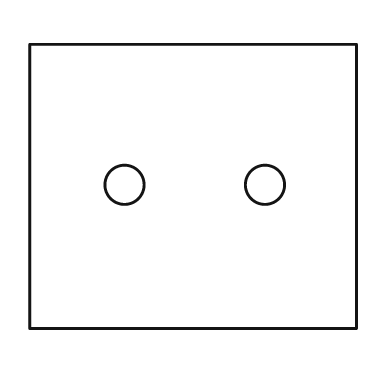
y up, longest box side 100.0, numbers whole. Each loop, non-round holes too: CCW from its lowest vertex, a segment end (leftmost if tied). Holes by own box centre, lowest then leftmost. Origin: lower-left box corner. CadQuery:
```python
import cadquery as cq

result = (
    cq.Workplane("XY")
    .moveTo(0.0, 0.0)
    .lineTo(100.0, 0.0)
    .lineTo(100.0, 87.0)
    .lineTo(0.0, 87.0)
    .close()
    .moveTo(29.0, 44.0)
    .circle(6.0)
    .moveTo(72.0, 44.0)
    .circle(6.0)
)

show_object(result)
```